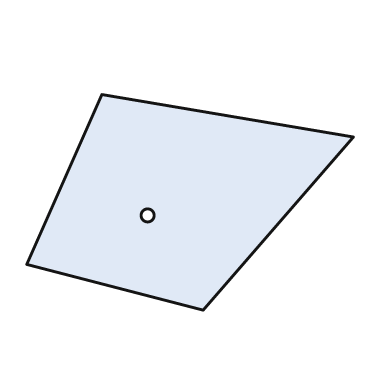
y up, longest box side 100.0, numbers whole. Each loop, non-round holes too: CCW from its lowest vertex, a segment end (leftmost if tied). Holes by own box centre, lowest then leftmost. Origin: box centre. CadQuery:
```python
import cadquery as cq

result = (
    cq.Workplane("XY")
    .moveTo(4.0, -33.0)
    .lineTo(50.0, 20.0)
    .lineTo(-27.0, 33.0)
    .lineTo(-50.0, -19.0)
    .close()
    .moveTo(-13.0, -4.0)
    .circle(2.0)
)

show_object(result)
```